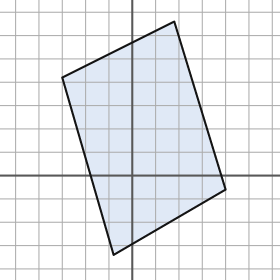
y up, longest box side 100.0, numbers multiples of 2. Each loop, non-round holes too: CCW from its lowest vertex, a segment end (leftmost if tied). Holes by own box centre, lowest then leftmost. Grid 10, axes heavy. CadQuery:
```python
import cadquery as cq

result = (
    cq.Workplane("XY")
    .moveTo(-8.0, -34.0)
    .lineTo(40.0, -6.0)
    .lineTo(18.0, 66.0)
    .lineTo(-30.0, 42.0)
    .close()
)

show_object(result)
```